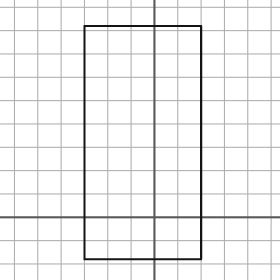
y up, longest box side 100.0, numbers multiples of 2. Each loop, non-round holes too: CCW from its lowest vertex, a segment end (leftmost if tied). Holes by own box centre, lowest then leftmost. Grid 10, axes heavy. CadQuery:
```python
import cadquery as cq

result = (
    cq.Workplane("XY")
    .moveTo(-30.0, -18.0)
    .lineTo(20.0, -18.0)
    .lineTo(20.0, 82.0)
    .lineTo(-30.0, 82.0)
    .close()
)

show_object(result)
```